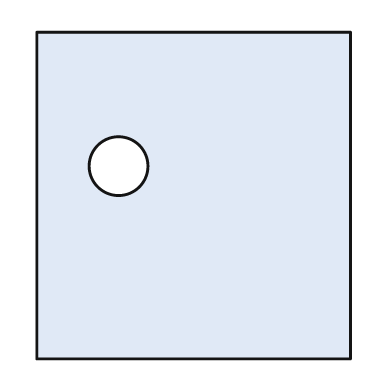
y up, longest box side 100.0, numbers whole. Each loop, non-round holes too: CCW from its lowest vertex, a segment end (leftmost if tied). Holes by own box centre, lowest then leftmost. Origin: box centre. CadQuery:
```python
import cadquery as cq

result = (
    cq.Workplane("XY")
    .moveTo(-48.0, -50.0)
    .lineTo(48.0, -50.0)
    .lineTo(48.0, 50.0)
    .lineTo(-48.0, 50.0)
    .close()
    .moveTo(-23.0, 9.0)
    .circle(9.0)
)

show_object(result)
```